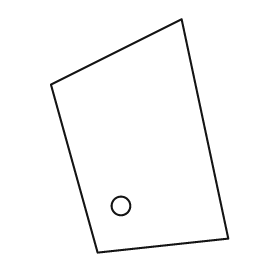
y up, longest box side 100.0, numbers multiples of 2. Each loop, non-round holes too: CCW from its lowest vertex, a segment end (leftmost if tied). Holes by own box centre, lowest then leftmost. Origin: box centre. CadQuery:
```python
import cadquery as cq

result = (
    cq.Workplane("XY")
    .moveTo(-18.0, -50.0)
    .lineTo(38.0, -44.0)
    .lineTo(18.0, 50.0)
    .lineTo(-38.0, 22.0)
    .close()
    .moveTo(-8.0, -30.0)
    .circle(4.0)
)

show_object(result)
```